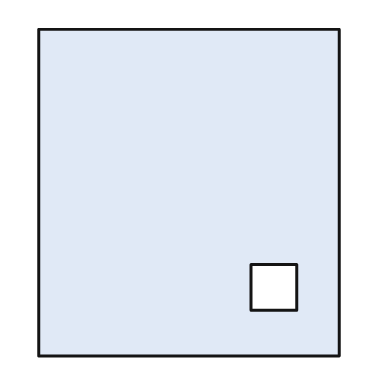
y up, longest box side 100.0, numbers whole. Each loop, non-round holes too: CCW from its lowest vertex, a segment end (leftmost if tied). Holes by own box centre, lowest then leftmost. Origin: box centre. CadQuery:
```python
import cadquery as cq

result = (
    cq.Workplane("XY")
    .moveTo(-46.0, -50.0)
    .lineTo(46.0, -50.0)
    .lineTo(46.0, 50.0)
    .lineTo(-46.0, 50.0)
    .close()
    .moveTo(19.0, -36.0)
    .lineTo(33.0, -36.0)
    .lineTo(33.0, -22.0)
    .lineTo(19.0, -22.0)
    .close()
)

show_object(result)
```